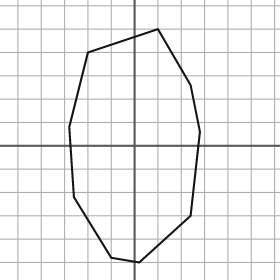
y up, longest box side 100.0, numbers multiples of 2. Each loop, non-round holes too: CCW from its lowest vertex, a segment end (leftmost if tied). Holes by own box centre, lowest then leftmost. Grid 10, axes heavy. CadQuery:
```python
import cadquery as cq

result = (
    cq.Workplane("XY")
    .moveTo(2.0, -50.0)
    .lineTo(24.0, -30.0)
    .lineTo(28.0, 6.0)
    .lineTo(24.0, 26.0)
    .lineTo(10.0, 50.0)
    .lineTo(-20.0, 40.0)
    .lineTo(-28.0, 8.0)
    .lineTo(-26.0, -22.0)
    .lineTo(-10.0, -48.0)
    .close()
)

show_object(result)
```